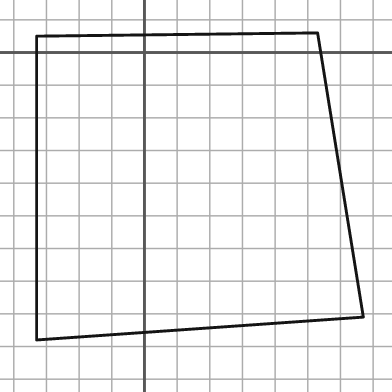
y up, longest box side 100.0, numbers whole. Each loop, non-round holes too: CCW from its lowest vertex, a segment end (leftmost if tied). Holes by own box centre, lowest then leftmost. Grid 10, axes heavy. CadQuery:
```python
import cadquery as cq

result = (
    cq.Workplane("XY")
    .moveTo(-33.0, -88.0)
    .lineTo(67.0, -81.0)
    .lineTo(53.0, 6.0)
    .lineTo(-33.0, 5.0)
    .close()
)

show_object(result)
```